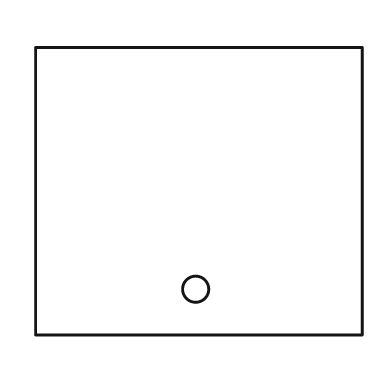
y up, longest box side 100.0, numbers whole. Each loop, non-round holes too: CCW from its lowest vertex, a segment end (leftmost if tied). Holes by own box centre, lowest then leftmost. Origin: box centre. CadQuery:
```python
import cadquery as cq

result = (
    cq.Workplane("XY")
    .moveTo(-50.0, -44.0)
    .lineTo(50.0, -44.0)
    .lineTo(50.0, 44.0)
    .lineTo(-50.0, 44.0)
    .close()
    .moveTo(-1.0, -30.0)
    .circle(4.0)
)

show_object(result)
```